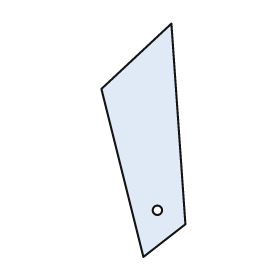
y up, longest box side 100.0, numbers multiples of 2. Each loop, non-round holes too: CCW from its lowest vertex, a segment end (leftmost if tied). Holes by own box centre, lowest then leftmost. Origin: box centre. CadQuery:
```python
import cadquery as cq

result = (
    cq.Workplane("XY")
    .moveTo(0.0, -50.0)
    .lineTo(18.0, -36.0)
    .lineTo(12.0, 50.0)
    .lineTo(-18.0, 22.0)
    .close()
    .moveTo(6.0, -30.0)
    .circle(2.0)
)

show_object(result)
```